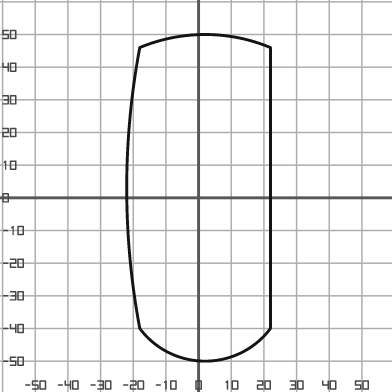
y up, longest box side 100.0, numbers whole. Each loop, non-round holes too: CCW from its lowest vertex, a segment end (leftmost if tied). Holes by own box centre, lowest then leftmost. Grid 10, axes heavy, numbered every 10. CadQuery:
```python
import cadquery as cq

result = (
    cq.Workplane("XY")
    .moveTo(-18.0, -40.0)
    .threePointArc((2.0, -50.0), (22.0, -40.0))
    .lineTo(22.0, 46.0)
    .threePointArc((2.0, 50.0), (-18.0, 46.0))
    .threePointArc((-22.0, 3.0), (-18.0, -40.0))
    .close()
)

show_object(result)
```